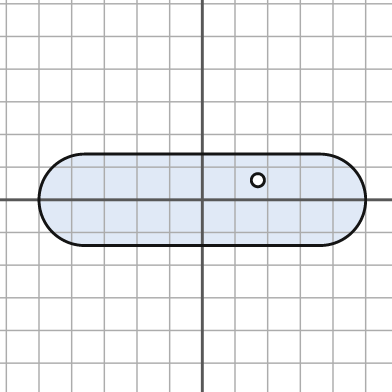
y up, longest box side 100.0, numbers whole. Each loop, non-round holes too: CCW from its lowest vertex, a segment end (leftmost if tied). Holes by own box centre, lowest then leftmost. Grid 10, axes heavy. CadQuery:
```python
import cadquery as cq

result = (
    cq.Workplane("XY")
    .moveTo(-36.0, -14.0)
    .lineTo(36.0, -14.0)
    .threePointArc((50.0, 0.0), (36.0, 14.0))
    .lineTo(-36.0, 14.0)
    .threePointArc((-50.0, 0.0), (-36.0, -14.0))
    .close()
    .moveTo(17.0, 6.0)
    .circle(2.0)
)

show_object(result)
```